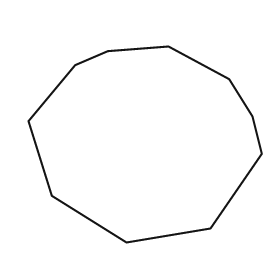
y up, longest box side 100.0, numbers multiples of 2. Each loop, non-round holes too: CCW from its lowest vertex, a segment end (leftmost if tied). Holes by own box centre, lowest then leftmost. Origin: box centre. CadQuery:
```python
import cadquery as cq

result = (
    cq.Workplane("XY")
    .moveTo(-8.0, -42.0)
    .lineTo(28.0, -36.0)
    .lineTo(50.0, -4.0)
    .lineTo(46.0, 12.0)
    .lineTo(36.0, 28.0)
    .lineTo(10.0, 42.0)
    .lineTo(-16.0, 40.0)
    .lineTo(-30.0, 34.0)
    .lineTo(-50.0, 10.0)
    .lineTo(-40.0, -22.0)
    .close()
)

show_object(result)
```